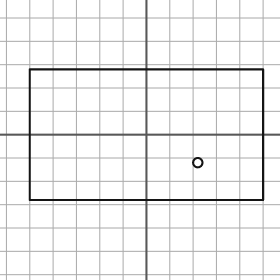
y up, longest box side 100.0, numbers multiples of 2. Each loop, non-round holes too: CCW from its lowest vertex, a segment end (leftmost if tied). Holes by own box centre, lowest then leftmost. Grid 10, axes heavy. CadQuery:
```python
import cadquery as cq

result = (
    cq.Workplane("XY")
    .moveTo(-50.0, -28.0)
    .lineTo(50.0, -28.0)
    .lineTo(50.0, 28.0)
    .lineTo(-50.0, 28.0)
    .close()
    .moveTo(22.0, -12.0)
    .circle(2.0)
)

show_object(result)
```